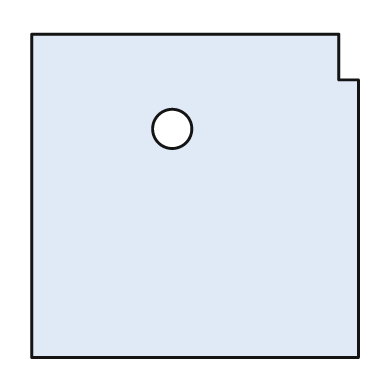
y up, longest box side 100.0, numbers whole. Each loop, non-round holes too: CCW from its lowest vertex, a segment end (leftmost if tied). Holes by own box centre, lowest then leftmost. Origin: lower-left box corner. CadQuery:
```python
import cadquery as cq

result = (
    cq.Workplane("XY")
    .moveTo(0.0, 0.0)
    .lineTo(100.0, 0.0)
    .lineTo(100.0, 85.0)
    .lineTo(94.0, 85.0)
    .lineTo(94.0, 99.0)
    .lineTo(0.0, 99.0)
    .close()
    .moveTo(43.0, 70.0)
    .circle(6.0)
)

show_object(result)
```